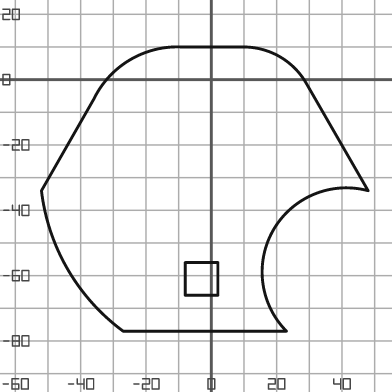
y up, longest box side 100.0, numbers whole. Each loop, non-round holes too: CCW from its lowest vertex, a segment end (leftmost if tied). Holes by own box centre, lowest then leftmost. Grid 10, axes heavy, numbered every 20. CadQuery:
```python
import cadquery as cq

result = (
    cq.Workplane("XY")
    .moveTo(-27.0, -77.0)
    .lineTo(23.0, -77.0)
    .threePointArc((19.0, -46.0), (48.0, -34.0))
    .lineTo(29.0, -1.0)
    .threePointArc((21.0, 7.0), (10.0, 10.0))
    .lineTo(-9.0, 10.0)
    .threePointArc((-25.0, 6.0), (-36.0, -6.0))
    .lineTo(-52.0, -34.0)
    .threePointArc((-44.0, -58.0), (-27.0, -77.0))
    .close()
    .moveTo(-8.0, -66.0)
    .lineTo(2.0, -66.0)
    .lineTo(2.0, -56.0)
    .lineTo(-8.0, -56.0)
    .close()
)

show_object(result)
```